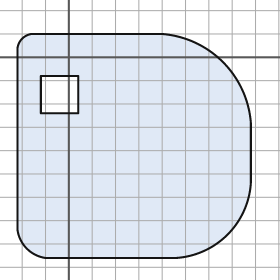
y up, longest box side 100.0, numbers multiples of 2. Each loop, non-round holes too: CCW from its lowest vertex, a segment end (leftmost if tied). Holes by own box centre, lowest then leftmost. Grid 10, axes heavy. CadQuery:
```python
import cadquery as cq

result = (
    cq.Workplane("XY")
    .moveTo(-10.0, -86.0)
    .lineTo(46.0, -86.0)
    .threePointArc((68.0, -76.0), (78.0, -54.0))
    .lineTo(78.0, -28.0)
    .threePointArc((66.0, -2.0), (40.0, 10.0))
    .lineTo(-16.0, 10.0)
    .threePointArc((-20.0, 8.0), (-22.0, 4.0))
    .lineTo(-22.0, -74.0)
    .threePointArc((-18.0, -82.0), (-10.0, -86.0))
    .close()
    .moveTo(-12.0, -24.0)
    .lineTo(4.0, -24.0)
    .lineTo(4.0, -8.0)
    .lineTo(-12.0, -8.0)
    .close()
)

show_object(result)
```